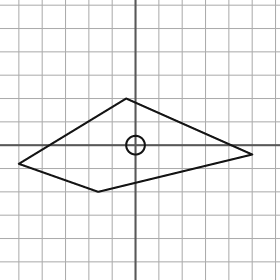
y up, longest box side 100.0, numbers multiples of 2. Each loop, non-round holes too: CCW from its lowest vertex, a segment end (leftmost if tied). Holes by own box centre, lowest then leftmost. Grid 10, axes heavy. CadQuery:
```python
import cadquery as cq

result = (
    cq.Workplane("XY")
    .moveTo(-16.0, -20.0)
    .lineTo(50.0, -4.0)
    .lineTo(-4.0, 20.0)
    .lineTo(-50.0, -8.0)
    .close()
    .moveTo(0.0, 0.0)
    .circle(4.0)
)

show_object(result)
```